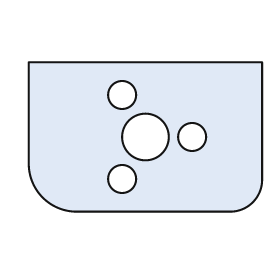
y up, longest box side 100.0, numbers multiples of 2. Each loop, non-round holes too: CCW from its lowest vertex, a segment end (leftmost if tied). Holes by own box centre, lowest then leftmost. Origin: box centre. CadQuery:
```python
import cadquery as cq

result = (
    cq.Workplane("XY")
    .moveTo(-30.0, -32.0)
    .lineTo(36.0, -32.0)
    .threePointArc((46.0, -28.0), (50.0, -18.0))
    .lineTo(50.0, 32.0)
    .lineTo(-50.0, 32.0)
    .lineTo(-50.0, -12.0)
    .threePointArc((-44.0, -26.0), (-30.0, -32.0))
    .close()
    .moveTo(-10.0, -18.0)
    .circle(6.0)
    .moveTo(0.0, 0.0)
    .circle(10.0)
    .moveTo(20.0, 0.0)
    .circle(6.0)
    .moveTo(-10.0, 18.0)
    .circle(6.0)
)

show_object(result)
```